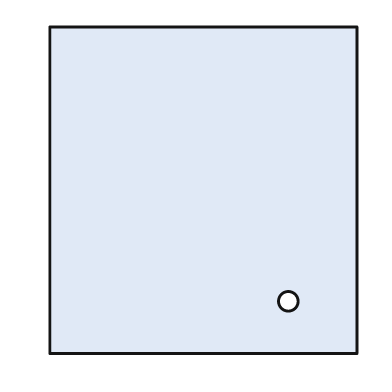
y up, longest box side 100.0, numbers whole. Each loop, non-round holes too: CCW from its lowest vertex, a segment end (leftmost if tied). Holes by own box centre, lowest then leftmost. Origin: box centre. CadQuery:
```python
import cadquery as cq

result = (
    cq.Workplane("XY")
    .moveTo(-47.0, -50.0)
    .lineTo(47.0, -50.0)
    .lineTo(47.0, 50.0)
    .lineTo(-47.0, 50.0)
    .close()
    .moveTo(26.0, -34.0)
    .circle(3.0)
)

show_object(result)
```